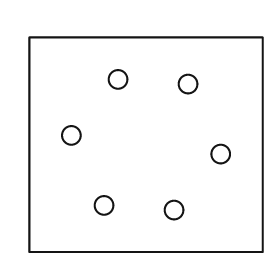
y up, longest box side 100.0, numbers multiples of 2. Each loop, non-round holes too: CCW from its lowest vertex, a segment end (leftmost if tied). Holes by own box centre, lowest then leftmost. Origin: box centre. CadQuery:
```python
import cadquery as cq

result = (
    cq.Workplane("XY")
    .moveTo(-50.0, -46.0)
    .lineTo(50.0, -46.0)
    .lineTo(50.0, 46.0)
    .lineTo(-50.0, 46.0)
    .close()
    .moveTo(12.0, -28.0)
    .circle(4.0)
    .moveTo(-18.0, -26.0)
    .circle(4.0)
    .moveTo(32.0, -4.0)
    .circle(4.0)
    .moveTo(-32.0, 4.0)
    .circle(4.0)
    .moveTo(18.0, 26.0)
    .circle(4.0)
    .moveTo(-12.0, 28.0)
    .circle(4.0)
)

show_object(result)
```